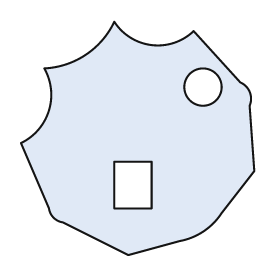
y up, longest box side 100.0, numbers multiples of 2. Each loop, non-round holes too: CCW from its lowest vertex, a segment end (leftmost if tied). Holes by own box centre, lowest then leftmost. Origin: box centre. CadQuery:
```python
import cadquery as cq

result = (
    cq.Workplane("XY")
    .moveTo(-4.0, -50.0)
    .lineTo(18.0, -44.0)
    .threePointArc((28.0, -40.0), (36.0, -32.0))
    .lineTo(50.0, -14.0)
    .lineTo(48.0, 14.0)
    .threePointArc((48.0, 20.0), (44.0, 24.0))
    .lineTo(24.0, 46.0)
    .threePointArc((6.0, 40.0), (-10.0, 50.0))
    .threePointArc((-22.0, 36.0), (-40.0, 30.0))
    .threePointArc((-38.0, 12.0), (-50.0, -2.0))
    .lineTo(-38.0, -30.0)
    .threePointArc((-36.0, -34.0), (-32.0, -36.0))
    .close()
    .moveTo(-10.0, -30.0)
    .lineTo(6.0, -30.0)
    .lineTo(6.0, -10.0)
    .lineTo(-10.0, -10.0)
    .close()
    .moveTo(28.0, 22.0)
    .circle(8.0)
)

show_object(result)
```